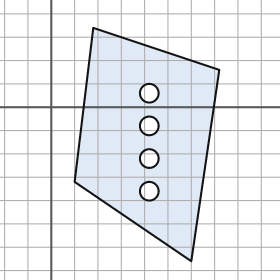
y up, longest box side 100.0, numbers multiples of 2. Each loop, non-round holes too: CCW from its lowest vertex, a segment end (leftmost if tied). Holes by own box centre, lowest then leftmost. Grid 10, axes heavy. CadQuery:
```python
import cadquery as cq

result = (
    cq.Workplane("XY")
    .moveTo(60.0, -66.0)
    .lineTo(72.0, 16.0)
    .lineTo(18.0, 34.0)
    .lineTo(10.0, -32.0)
    .close()
    .moveTo(42.0, -36.0)
    .circle(4.0)
    .moveTo(42.0, -22.0)
    .circle(4.0)
    .moveTo(42.0, -8.0)
    .circle(4.0)
    .moveTo(42.0, 6.0)
    .circle(4.0)
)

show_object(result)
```